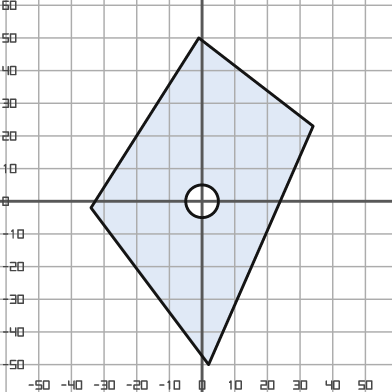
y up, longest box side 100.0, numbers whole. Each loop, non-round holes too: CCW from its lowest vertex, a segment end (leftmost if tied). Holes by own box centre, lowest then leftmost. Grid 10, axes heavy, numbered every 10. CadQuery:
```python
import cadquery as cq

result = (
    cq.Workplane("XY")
    .moveTo(2.0, -50.0)
    .lineTo(34.0, 23.0)
    .lineTo(-1.0, 50.0)
    .lineTo(-34.0, -2.0)
    .close()
    .moveTo(0.0, 0.0)
    .circle(5.0)
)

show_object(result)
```